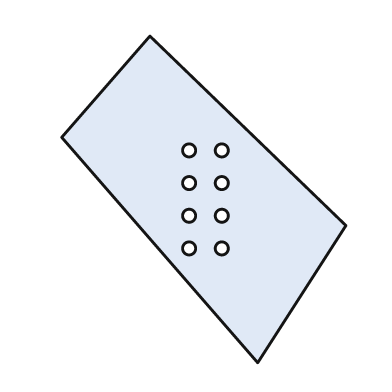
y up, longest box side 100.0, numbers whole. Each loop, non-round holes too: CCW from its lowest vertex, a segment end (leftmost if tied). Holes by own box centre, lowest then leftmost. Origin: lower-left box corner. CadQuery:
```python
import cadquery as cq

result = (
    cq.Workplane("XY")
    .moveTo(60.0, 0.0)
    .lineTo(87.0, 42.0)
    .lineTo(27.0, 100.0)
    .lineTo(0.0, 69.0)
    .close()
    .moveTo(39.0, 35.0)
    .circle(2.0)
    .moveTo(49.0, 35.0)
    .circle(2.0)
    .moveTo(39.0, 45.0)
    .circle(2.0)
    .moveTo(49.0, 45.0)
    .circle(2.0)
    .moveTo(39.0, 55.0)
    .circle(2.0)
    .moveTo(49.0, 55.0)
    .circle(2.0)
    .moveTo(39.0, 65.0)
    .circle(2.0)
    .moveTo(49.0, 65.0)
    .circle(2.0)
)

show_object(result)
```